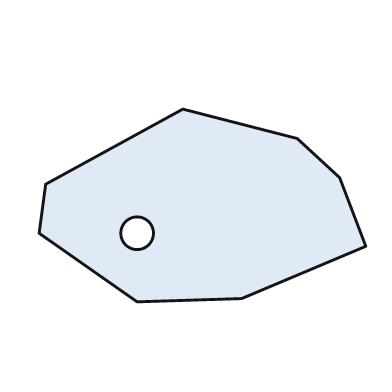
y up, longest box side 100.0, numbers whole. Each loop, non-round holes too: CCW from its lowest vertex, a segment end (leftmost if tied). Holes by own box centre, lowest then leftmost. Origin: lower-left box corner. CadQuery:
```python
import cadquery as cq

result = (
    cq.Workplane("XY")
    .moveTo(30.0, 0.0)
    .lineTo(62.0, 1.0)
    .lineTo(100.0, 17.0)
    .lineTo(92.0, 38.0)
    .lineTo(79.0, 50.0)
    .lineTo(44.0, 59.0)
    .lineTo(2.0, 36.0)
    .lineTo(0.0, 21.0)
    .close()
    .moveTo(30.0, 21.0)
    .circle(5.0)
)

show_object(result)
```